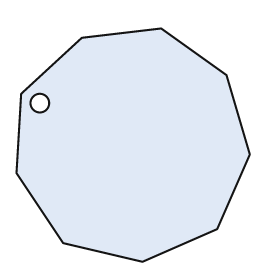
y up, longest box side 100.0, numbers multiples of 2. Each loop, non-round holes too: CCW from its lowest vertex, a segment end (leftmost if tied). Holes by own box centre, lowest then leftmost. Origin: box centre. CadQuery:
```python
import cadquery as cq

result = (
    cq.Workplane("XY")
    .moveTo(4.0, -50.0)
    .lineTo(36.0, -36.0)
    .lineTo(50.0, -4.0)
    .lineTo(40.0, 30.0)
    .lineTo(12.0, 50.0)
    .lineTo(-22.0, 46.0)
    .lineTo(-48.0, 22.0)
    .lineTo(-50.0, -12.0)
    .lineTo(-30.0, -42.0)
    .close()
    .moveTo(-40.0, 18.0)
    .circle(4.0)
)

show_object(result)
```